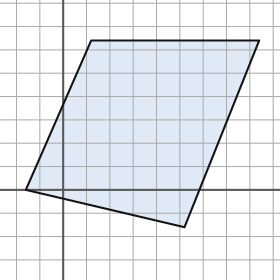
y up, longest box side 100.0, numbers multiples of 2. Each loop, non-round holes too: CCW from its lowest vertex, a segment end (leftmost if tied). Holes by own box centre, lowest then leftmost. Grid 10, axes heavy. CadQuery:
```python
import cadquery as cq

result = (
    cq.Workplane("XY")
    .moveTo(52.0, -16.0)
    .lineTo(84.0, 64.0)
    .lineTo(12.0, 64.0)
    .lineTo(-16.0, 0.0)
    .close()
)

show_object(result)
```